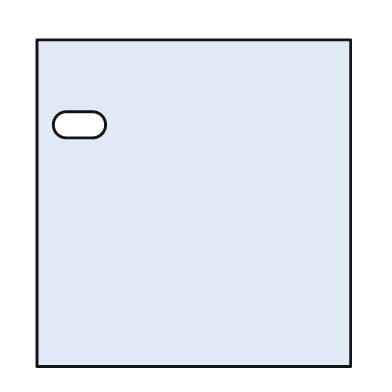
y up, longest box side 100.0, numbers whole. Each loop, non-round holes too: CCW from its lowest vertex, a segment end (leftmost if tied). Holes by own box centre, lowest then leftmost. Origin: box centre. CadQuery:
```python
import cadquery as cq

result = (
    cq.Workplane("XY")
    .moveTo(-48.0, -50.0)
    .lineTo(48.0, -50.0)
    .lineTo(48.0, 50.0)
    .lineTo(-48.0, 50.0)
    .close()
    .moveTo(-39.0, 20.0)
    .lineTo(-31.0, 20.0)
    .threePointArc((-27.0, 24.0), (-31.0, 28.0))
    .lineTo(-39.0, 28.0)
    .threePointArc((-43.0, 24.0), (-39.0, 20.0))
    .close()
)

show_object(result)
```